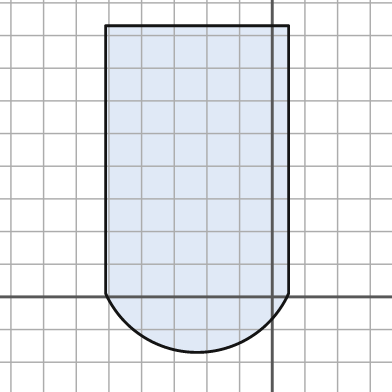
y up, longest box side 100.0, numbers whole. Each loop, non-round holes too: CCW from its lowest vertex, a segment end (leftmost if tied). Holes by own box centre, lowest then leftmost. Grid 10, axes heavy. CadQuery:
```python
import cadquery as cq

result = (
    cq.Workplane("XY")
    .moveTo(-51.0, 1.0)
    .threePointArc((-23.0, -17.0), (5.0, 1.0))
    .lineTo(5.0, 83.0)
    .lineTo(-51.0, 83.0)
    .close()
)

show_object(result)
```